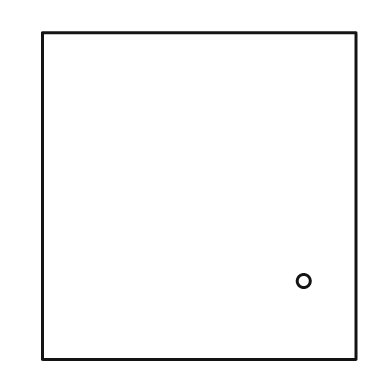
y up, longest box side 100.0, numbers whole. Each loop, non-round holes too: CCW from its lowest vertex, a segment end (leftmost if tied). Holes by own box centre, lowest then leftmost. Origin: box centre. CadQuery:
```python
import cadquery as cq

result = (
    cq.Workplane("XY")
    .moveTo(-48.0, -50.0)
    .lineTo(48.0, -50.0)
    .lineTo(48.0, 50.0)
    .lineTo(-48.0, 50.0)
    .close()
    .moveTo(32.0, -26.0)
    .circle(2.0)
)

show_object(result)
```